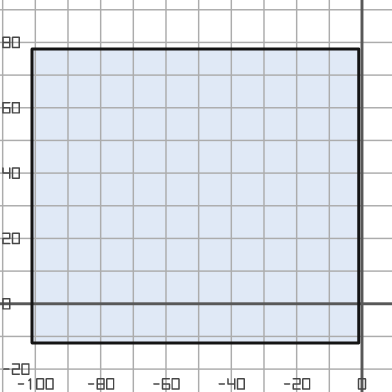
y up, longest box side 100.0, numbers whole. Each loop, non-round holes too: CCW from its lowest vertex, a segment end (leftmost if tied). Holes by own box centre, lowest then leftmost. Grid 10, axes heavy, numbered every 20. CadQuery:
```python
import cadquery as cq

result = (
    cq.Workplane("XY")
    .moveTo(-101.0, -12.0)
    .lineTo(-1.0, -12.0)
    .lineTo(-1.0, 78.0)
    .lineTo(-101.0, 78.0)
    .close()
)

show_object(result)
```